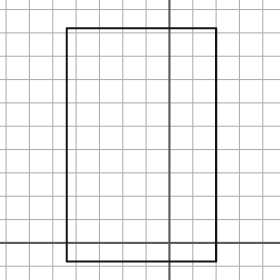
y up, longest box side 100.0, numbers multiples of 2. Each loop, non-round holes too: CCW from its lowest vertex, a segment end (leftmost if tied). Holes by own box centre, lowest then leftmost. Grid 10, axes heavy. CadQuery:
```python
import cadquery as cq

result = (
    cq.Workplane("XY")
    .moveTo(-44.0, -8.0)
    .lineTo(20.0, -8.0)
    .lineTo(20.0, 92.0)
    .lineTo(-44.0, 92.0)
    .close()
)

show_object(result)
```